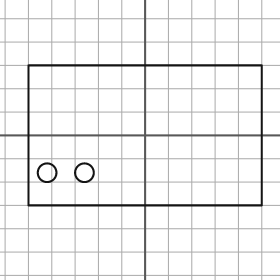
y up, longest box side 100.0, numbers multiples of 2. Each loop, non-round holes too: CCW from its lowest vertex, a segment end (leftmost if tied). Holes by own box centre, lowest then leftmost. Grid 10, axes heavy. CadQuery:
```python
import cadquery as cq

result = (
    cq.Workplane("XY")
    .moveTo(-50.0, -30.0)
    .lineTo(50.0, -30.0)
    .lineTo(50.0, 30.0)
    .lineTo(-50.0, 30.0)
    .close()
    .moveTo(-42.0, -16.0)
    .circle(4.0)
    .moveTo(-26.0, -16.0)
    .circle(4.0)
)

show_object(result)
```